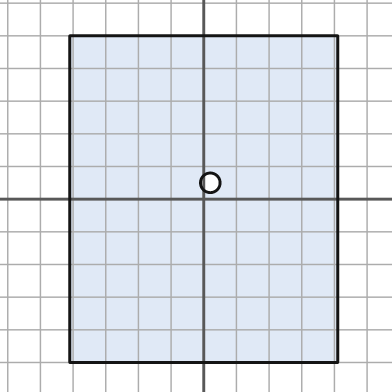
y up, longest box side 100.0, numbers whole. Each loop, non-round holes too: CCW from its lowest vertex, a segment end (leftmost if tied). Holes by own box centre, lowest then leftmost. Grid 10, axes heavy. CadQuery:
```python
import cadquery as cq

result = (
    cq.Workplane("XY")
    .moveTo(-41.0, -50.0)
    .lineTo(41.0, -50.0)
    .lineTo(41.0, 50.0)
    .lineTo(-41.0, 50.0)
    .close()
    .moveTo(2.0, 5.0)
    .circle(3.0)
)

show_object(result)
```